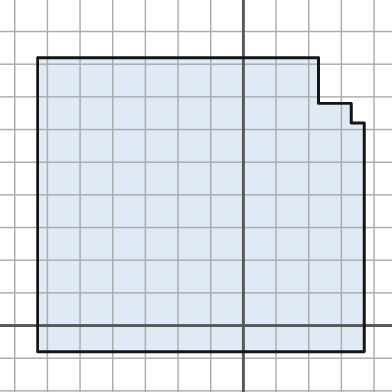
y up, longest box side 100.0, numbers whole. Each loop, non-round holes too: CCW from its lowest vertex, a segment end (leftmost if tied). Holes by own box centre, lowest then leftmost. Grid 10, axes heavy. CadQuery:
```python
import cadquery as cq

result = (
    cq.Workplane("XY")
    .moveTo(-63.0, -8.0)
    .lineTo(37.0, -8.0)
    .lineTo(37.0, 62.0)
    .lineTo(33.0, 62.0)
    .lineTo(33.0, 68.0)
    .lineTo(23.0, 68.0)
    .lineTo(23.0, 82.0)
    .lineTo(-63.0, 82.0)
    .close()
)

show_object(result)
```